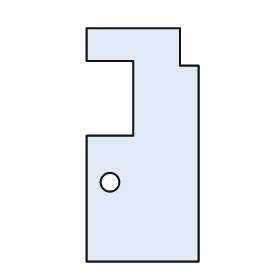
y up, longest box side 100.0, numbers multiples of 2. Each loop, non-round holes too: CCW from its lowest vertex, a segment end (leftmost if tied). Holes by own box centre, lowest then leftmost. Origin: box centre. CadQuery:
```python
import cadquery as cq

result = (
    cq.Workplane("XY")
    .moveTo(-24.0, -50.0)
    .lineTo(24.0, -50.0)
    .lineTo(24.0, 34.0)
    .lineTo(16.0, 34.0)
    .lineTo(16.0, 50.0)
    .lineTo(-24.0, 50.0)
    .lineTo(-24.0, 36.0)
    .lineTo(-4.0, 36.0)
    .lineTo(-4.0, 4.0)
    .lineTo(-24.0, 4.0)
    .close()
    .moveTo(-14.0, -16.0)
    .circle(4.0)
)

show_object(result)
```